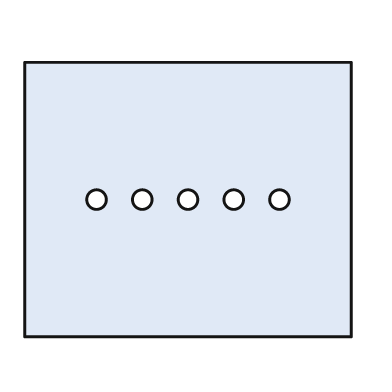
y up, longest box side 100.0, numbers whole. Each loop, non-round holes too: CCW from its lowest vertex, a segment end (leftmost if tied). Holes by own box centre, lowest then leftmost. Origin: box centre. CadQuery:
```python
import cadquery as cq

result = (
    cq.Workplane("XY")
    .moveTo(-50.0, -42.0)
    .lineTo(50.0, -42.0)
    .lineTo(50.0, 42.0)
    .lineTo(-50.0, 42.0)
    .close()
    .moveTo(-28.0, 0.0)
    .circle(3.0)
    .moveTo(-14.0, 0.0)
    .circle(3.0)
    .moveTo(0.0, 0.0)
    .circle(3.0)
    .moveTo(14.0, 0.0)
    .circle(3.0)
    .moveTo(28.0, 0.0)
    .circle(3.0)
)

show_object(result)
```